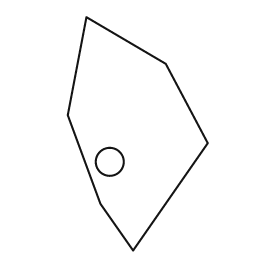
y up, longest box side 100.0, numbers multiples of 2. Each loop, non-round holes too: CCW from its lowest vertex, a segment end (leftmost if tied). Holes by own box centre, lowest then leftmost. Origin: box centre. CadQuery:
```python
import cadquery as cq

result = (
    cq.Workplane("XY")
    .moveTo(-2.0, -50.0)
    .lineTo(30.0, -4.0)
    .lineTo(12.0, 30.0)
    .lineTo(-22.0, 50.0)
    .lineTo(-30.0, 8.0)
    .lineTo(-16.0, -30.0)
    .close()
    .moveTo(-12.0, -12.0)
    .circle(6.0)
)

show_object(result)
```